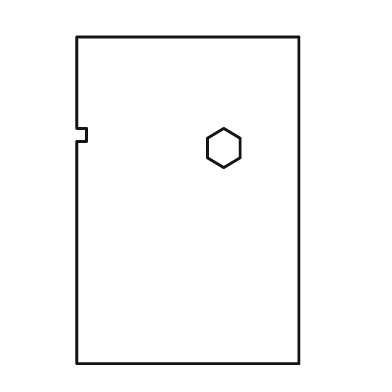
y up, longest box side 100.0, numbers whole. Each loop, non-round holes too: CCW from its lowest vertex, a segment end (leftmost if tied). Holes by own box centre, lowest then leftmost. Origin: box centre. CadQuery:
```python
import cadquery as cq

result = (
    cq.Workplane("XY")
    .moveTo(-34.0, -50.0)
    .lineTo(34.0, -50.0)
    .lineTo(34.0, 50.0)
    .lineTo(-34.0, 50.0)
    .lineTo(-34.0, 22.0)
    .lineTo(-31.0, 22.0)
    .lineTo(-31.0, 18.0)
    .lineTo(-34.0, 18.0)
    .close()
    .moveTo(11.0, 10.0)
    .lineTo(16.0, 13.0)
    .lineTo(16.0, 19.0)
    .lineTo(11.0, 22.0)
    .lineTo(6.0, 19.0)
    .lineTo(6.0, 13.0)
    .close()
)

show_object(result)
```